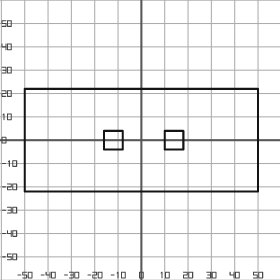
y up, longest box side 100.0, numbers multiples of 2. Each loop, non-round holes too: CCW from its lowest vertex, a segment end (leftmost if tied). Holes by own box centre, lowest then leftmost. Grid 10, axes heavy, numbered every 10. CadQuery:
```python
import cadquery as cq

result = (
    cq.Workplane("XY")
    .moveTo(-50.0, -22.0)
    .lineTo(50.0, -22.0)
    .lineTo(50.0, 22.0)
    .lineTo(-50.0, 22.0)
    .close()
    .moveTo(-16.0, -4.0)
    .lineTo(-8.0, -4.0)
    .lineTo(-8.0, 4.0)
    .lineTo(-16.0, 4.0)
    .close()
    .moveTo(10.0, -4.0)
    .lineTo(18.0, -4.0)
    .lineTo(18.0, 4.0)
    .lineTo(10.0, 4.0)
    .close()
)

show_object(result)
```